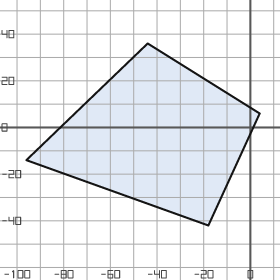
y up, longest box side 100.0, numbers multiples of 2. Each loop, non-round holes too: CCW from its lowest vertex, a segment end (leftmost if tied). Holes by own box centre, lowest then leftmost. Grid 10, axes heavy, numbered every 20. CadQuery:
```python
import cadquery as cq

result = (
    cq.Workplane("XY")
    .moveTo(-18.0, -42.0)
    .lineTo(4.0, 6.0)
    .lineTo(-44.0, 36.0)
    .lineTo(-96.0, -14.0)
    .close()
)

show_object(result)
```